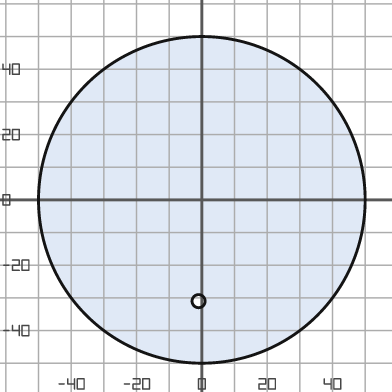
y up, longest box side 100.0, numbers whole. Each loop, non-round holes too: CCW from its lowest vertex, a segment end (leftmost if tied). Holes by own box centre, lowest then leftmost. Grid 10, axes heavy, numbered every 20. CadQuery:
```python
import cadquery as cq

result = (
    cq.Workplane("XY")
    .moveTo(0.0, 0.0)
    .circle(50.0)
    .moveTo(-1.0, -31.0)
    .circle(2.0)
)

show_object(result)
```